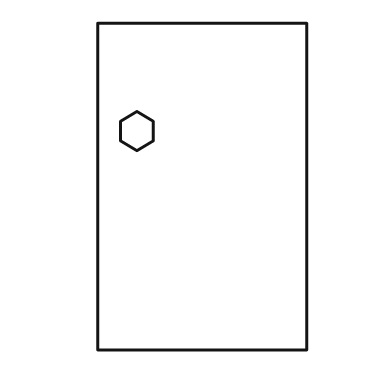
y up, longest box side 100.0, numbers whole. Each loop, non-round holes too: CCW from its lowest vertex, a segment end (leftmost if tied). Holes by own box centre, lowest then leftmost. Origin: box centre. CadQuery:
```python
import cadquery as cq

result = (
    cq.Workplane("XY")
    .moveTo(-32.0, -50.0)
    .lineTo(32.0, -50.0)
    .lineTo(32.0, 50.0)
    .lineTo(-32.0, 50.0)
    .close()
    .moveTo(-20.0, 11.0)
    .lineTo(-15.0, 14.0)
    .lineTo(-15.0, 20.0)
    .lineTo(-20.0, 23.0)
    .lineTo(-25.0, 20.0)
    .lineTo(-25.0, 14.0)
    .close()
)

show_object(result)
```